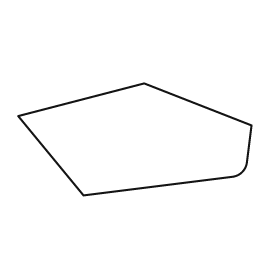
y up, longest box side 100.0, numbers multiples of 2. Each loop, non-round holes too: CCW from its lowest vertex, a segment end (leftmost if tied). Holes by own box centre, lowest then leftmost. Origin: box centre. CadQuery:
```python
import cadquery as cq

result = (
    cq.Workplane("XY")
    .moveTo(-22.0, -24.0)
    .lineTo(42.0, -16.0)
    .threePointArc((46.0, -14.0), (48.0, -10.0))
    .lineTo(50.0, 6.0)
    .lineTo(4.0, 24.0)
    .lineTo(-50.0, 10.0)
    .close()
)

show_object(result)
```